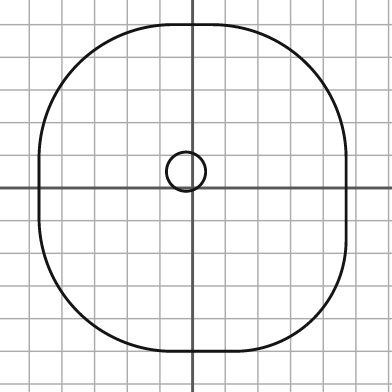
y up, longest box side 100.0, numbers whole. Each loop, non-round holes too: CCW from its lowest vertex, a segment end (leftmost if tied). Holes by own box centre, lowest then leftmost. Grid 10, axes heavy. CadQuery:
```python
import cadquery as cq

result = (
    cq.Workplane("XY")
    .moveTo(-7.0, -50.0)
    .lineTo(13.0, -50.0)
    .threePointArc((37.0, -40.0), (47.0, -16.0))
    .lineTo(47.0, 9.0)
    .threePointArc((35.0, 38.0), (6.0, 50.0))
    .lineTo(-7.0, 50.0)
    .threePointArc((-35.0, 38.0), (-47.0, 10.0))
    .lineTo(-47.0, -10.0)
    .threePointArc((-35.0, -38.0), (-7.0, -50.0))
    .close()
    .moveTo(-2.0, 5.0)
    .circle(6.0)
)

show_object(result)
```